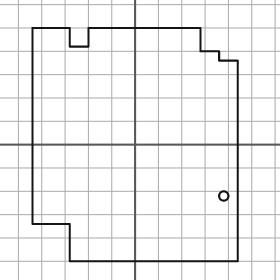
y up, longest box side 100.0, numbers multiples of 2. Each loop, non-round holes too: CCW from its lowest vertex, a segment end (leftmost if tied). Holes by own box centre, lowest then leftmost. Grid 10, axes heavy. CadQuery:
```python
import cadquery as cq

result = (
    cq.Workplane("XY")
    .moveTo(-28.0, -50.0)
    .lineTo(44.0, -50.0)
    .lineTo(44.0, 36.0)
    .lineTo(36.0, 36.0)
    .lineTo(36.0, 40.0)
    .lineTo(28.0, 40.0)
    .lineTo(28.0, 50.0)
    .lineTo(-20.0, 50.0)
    .lineTo(-20.0, 42.0)
    .lineTo(-28.0, 42.0)
    .lineTo(-28.0, 50.0)
    .lineTo(-44.0, 50.0)
    .lineTo(-44.0, -34.0)
    .lineTo(-28.0, -34.0)
    .close()
    .moveTo(38.0, -22.0)
    .circle(2.0)
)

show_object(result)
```